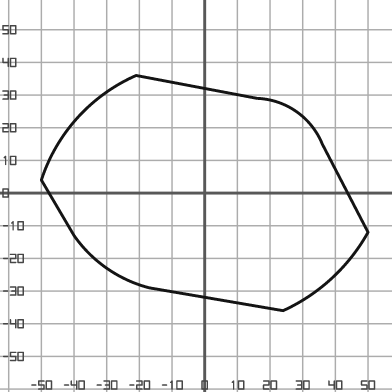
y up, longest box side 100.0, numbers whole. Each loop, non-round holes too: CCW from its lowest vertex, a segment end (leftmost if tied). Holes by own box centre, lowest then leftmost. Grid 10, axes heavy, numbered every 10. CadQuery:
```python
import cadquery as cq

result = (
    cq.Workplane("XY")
    .moveTo(24.0, -36.0)
    .threePointArc((39.0, -26.0), (50.0, -12.0))
    .lineTo(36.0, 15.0)
    .threePointArc((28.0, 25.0), (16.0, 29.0))
    .lineTo(-21.0, 36.0)
    .threePointArc((-39.0, 23.0), (-50.0, 4.0))
    .lineTo(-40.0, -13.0)
    .threePointArc((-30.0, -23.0), (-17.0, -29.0))
    .close()
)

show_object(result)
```